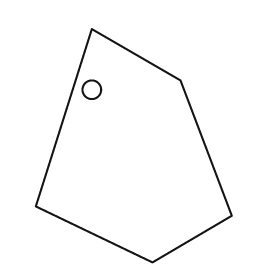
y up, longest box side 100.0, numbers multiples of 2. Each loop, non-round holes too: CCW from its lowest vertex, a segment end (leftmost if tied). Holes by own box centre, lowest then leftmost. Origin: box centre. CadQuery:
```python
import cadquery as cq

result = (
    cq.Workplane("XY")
    .moveTo(8.0, -50.0)
    .lineTo(42.0, -30.0)
    .lineTo(20.0, 28.0)
    .lineTo(-18.0, 50.0)
    .lineTo(-42.0, -26.0)
    .close()
    .moveTo(-18.0, 24.0)
    .circle(4.0)
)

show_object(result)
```